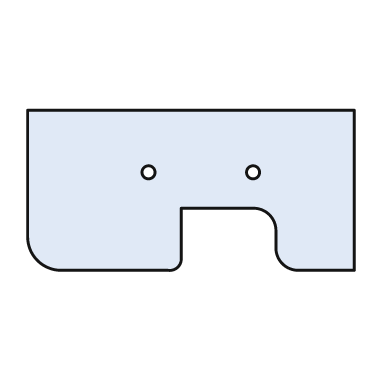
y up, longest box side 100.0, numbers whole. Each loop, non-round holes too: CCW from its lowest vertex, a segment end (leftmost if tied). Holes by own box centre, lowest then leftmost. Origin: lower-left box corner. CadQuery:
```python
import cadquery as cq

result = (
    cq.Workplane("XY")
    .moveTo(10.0, 0.0)
    .lineTo(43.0, 0.0)
    .threePointArc((46.0, 1.0), (47.0, 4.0))
    .lineTo(47.0, 19.0)
    .lineTo(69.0, 19.0)
    .threePointArc((74.0, 17.0), (76.0, 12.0))
    .lineTo(76.0, 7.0)
    .threePointArc((78.0, 2.0), (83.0, 0.0))
    .lineTo(100.0, 0.0)
    .lineTo(100.0, 49.0)
    .lineTo(0.0, 49.0)
    .lineTo(0.0, 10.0)
    .threePointArc((3.0, 3.0), (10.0, 0.0))
    .close()
    .moveTo(37.0, 30.0)
    .circle(2.0)
    .moveTo(69.0, 30.0)
    .circle(2.0)
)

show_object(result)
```